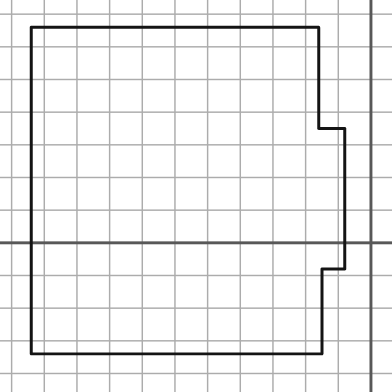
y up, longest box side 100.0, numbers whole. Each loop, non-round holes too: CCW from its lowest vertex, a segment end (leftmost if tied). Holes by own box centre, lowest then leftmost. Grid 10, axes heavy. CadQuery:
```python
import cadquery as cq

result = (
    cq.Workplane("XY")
    .moveTo(-104.0, -34.0)
    .lineTo(-15.0, -34.0)
    .lineTo(-15.0, -8.0)
    .lineTo(-8.0, -8.0)
    .lineTo(-8.0, 35.0)
    .lineTo(-16.0, 35.0)
    .lineTo(-16.0, 66.0)
    .lineTo(-104.0, 66.0)
    .close()
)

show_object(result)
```